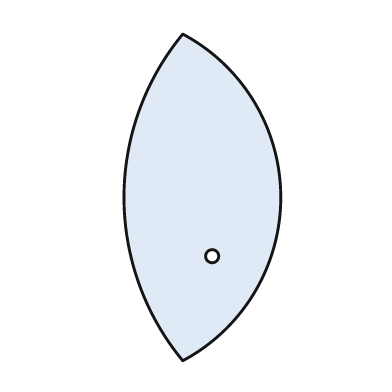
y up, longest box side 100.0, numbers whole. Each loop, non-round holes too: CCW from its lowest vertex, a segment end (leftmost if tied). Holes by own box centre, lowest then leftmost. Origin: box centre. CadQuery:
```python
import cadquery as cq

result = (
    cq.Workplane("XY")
    .moveTo(-6.0, -50.0)
    .threePointArc((24.0, 0.0), (-6.0, 50.0))
    .threePointArc((-24.0, 0.0), (-6.0, -50.0))
    .close()
    .moveTo(3.0, -18.0)
    .circle(2.0)
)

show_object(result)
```